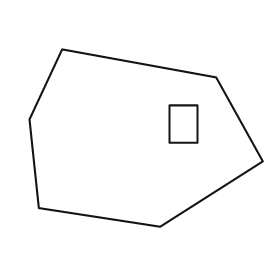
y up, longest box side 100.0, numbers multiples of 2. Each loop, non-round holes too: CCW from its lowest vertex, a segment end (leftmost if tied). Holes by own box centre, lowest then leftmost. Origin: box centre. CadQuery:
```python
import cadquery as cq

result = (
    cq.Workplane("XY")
    .moveTo(6.0, -38.0)
    .lineTo(50.0, -10.0)
    .lineTo(30.0, 26.0)
    .lineTo(-36.0, 38.0)
    .lineTo(-50.0, 8.0)
    .lineTo(-46.0, -30.0)
    .close()
    .moveTo(10.0, -2.0)
    .lineTo(22.0, -2.0)
    .lineTo(22.0, 14.0)
    .lineTo(10.0, 14.0)
    .close()
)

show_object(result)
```